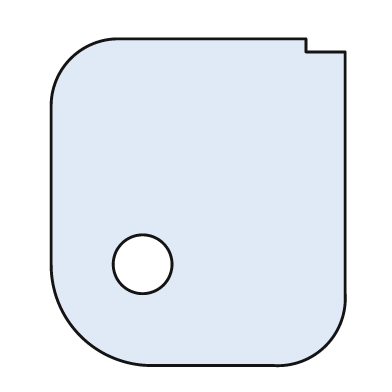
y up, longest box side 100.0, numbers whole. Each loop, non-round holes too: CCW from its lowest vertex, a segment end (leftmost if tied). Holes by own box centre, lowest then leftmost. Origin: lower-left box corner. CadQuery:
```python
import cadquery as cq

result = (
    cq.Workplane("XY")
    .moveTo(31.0, 0.0)
    .lineTo(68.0, 0.0)
    .threePointArc((84.0, 6.0), (90.0, 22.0))
    .lineTo(90.0, 96.0)
    .lineTo(78.0, 96.0)
    .lineTo(78.0, 100.0)
    .lineTo(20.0, 100.0)
    .threePointArc((6.0, 94.0), (0.0, 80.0))
    .lineTo(0.0, 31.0)
    .threePointArc((9.0, 9.0), (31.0, 0.0))
    .close()
    .moveTo(28.0, 31.0)
    .circle(9.0)
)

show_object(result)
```